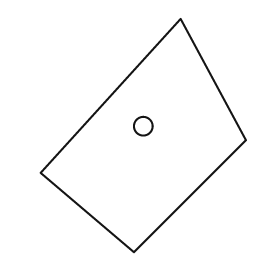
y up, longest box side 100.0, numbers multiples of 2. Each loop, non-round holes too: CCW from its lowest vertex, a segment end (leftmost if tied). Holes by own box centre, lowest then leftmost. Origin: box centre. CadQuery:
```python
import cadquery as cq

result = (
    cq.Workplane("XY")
    .moveTo(-4.0, -50.0)
    .lineTo(44.0, -2.0)
    .lineTo(16.0, 50.0)
    .lineTo(-44.0, -16.0)
    .close()
    .moveTo(0.0, 4.0)
    .circle(4.0)
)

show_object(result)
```